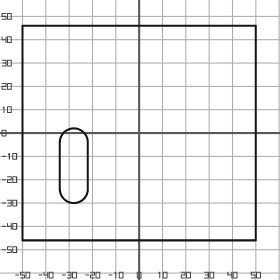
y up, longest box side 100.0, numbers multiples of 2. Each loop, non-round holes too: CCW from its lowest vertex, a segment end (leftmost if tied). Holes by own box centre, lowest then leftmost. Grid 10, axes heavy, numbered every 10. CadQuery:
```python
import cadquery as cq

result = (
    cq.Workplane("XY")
    .moveTo(-50.0, -46.0)
    .lineTo(50.0, -46.0)
    .lineTo(50.0, 46.0)
    .lineTo(-50.0, 46.0)
    .close()
    .moveTo(-34.0, -24.0)
    .threePointArc((-28.0, -30.0), (-22.0, -24.0))
    .lineTo(-22.0, -4.0)
    .threePointArc((-28.0, 2.0), (-34.0, -4.0))
    .close()
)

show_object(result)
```